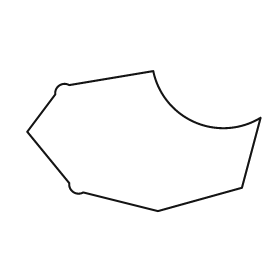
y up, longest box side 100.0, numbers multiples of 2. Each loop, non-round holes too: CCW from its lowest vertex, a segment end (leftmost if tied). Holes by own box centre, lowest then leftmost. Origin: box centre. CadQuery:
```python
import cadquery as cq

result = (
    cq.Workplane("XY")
    .moveTo(6.0, -30.0)
    .lineTo(42.0, -20.0)
    .lineTo(50.0, 10.0)
    .threePointArc((22.0, 8.0), (4.0, 30.0))
    .lineTo(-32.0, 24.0)
    .threePointArc((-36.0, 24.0), (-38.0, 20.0))
    .lineTo(-50.0, 4.0)
    .lineTo(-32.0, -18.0)
    .threePointArc((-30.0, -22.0), (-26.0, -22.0))
    .close()
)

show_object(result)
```